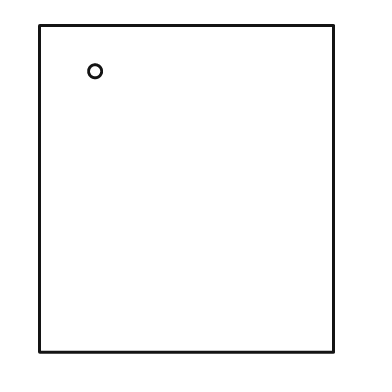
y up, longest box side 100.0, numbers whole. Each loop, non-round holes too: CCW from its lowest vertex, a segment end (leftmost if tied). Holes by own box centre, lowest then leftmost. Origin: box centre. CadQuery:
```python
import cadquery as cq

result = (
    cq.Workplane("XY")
    .moveTo(-45.0, -50.0)
    .lineTo(45.0, -50.0)
    .lineTo(45.0, 50.0)
    .lineTo(-45.0, 50.0)
    .close()
    .moveTo(-28.0, 36.0)
    .circle(2.0)
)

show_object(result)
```